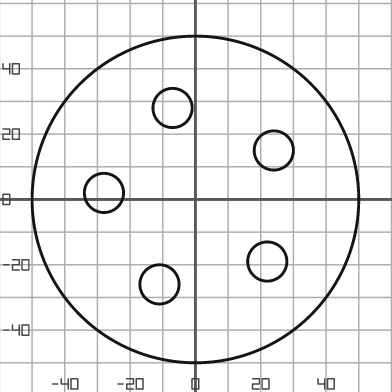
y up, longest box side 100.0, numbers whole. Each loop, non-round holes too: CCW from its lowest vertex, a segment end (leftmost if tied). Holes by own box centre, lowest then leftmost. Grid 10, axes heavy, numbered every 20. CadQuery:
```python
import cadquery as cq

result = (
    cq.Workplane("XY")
    .moveTo(0.0, 0.0)
    .circle(50.0)
    .moveTo(-11.0, -26.0)
    .circle(6.0)
    .moveTo(22.0, -19.0)
    .circle(6.0)
    .moveTo(-28.0, 2.0)
    .circle(6.0)
    .moveTo(24.0, 15.0)
    .circle(6.0)
    .moveTo(-7.0, 28.0)
    .circle(6.0)
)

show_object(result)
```